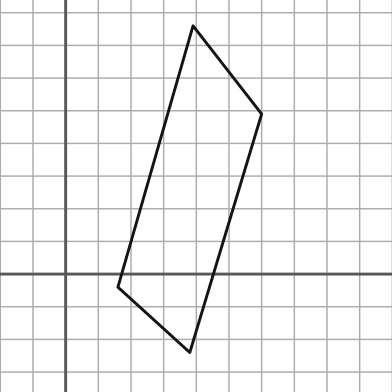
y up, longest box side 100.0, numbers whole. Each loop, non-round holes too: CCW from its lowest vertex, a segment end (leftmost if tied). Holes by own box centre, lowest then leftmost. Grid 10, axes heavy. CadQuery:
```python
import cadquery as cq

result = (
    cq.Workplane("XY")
    .moveTo(38.0, -24.0)
    .lineTo(60.0, 49.0)
    .lineTo(39.0, 76.0)
    .lineTo(16.0, -4.0)
    .close()
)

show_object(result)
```